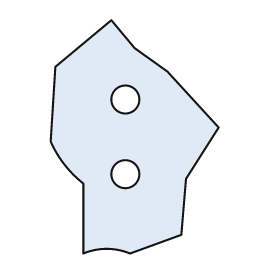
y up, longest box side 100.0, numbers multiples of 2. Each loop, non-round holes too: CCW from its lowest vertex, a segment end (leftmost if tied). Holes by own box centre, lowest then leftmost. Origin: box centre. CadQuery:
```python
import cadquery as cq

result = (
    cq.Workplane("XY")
    .moveTo(-22.0, -50.0)
    .threePointArc((-12.0, -48.0), (-2.0, -50.0))
    .lineTo(20.0, -42.0)
    .lineTo(22.0, -18.0)
    .lineTo(36.0, 4.0)
    .lineTo(14.0, 28.0)
    .lineTo(0.0, 38.0)
    .lineTo(-10.0, 50.0)
    .lineTo(-34.0, 30.0)
    .lineTo(-36.0, -2.0)
    .threePointArc((-30.0, -12.0), (-22.0, -20.0))
    .close()
    .moveTo(-4.0, -16.0)
    .circle(6.0)
    .moveTo(-4.0, 16.0)
    .circle(6.0)
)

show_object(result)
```